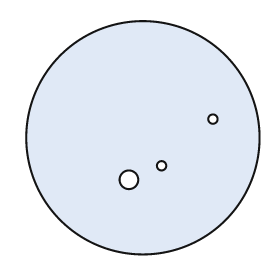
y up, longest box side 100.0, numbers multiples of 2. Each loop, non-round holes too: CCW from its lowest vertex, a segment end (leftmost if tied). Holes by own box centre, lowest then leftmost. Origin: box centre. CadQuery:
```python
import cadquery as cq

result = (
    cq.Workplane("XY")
    .moveTo(0.0, 0.0)
    .circle(50.0)
    .moveTo(-6.0, -18.0)
    .circle(4.0)
    .moveTo(8.0, -12.0)
    .circle(2.0)
    .moveTo(30.0, 8.0)
    .circle(2.0)
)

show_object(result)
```